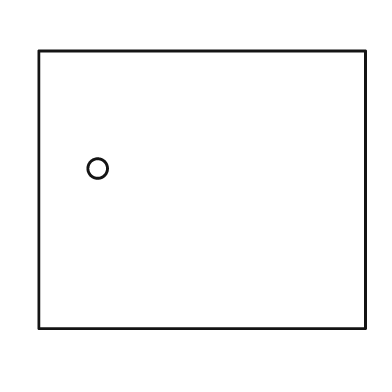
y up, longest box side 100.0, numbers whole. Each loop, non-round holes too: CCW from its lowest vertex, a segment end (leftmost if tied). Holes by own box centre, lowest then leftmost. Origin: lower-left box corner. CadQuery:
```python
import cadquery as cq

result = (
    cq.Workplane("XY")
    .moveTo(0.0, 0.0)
    .lineTo(100.0, 0.0)
    .lineTo(100.0, 85.0)
    .lineTo(0.0, 85.0)
    .close()
    .moveTo(18.0, 49.0)
    .circle(3.0)
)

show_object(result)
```